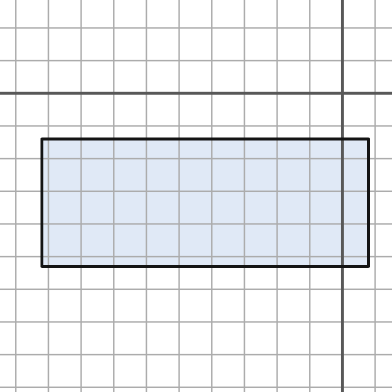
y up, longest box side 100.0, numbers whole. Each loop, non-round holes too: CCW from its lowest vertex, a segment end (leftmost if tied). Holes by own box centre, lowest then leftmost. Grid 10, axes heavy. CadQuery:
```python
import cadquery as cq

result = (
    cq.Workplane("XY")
    .moveTo(-92.0, -53.0)
    .lineTo(8.0, -53.0)
    .lineTo(8.0, -14.0)
    .lineTo(-92.0, -14.0)
    .close()
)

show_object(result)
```